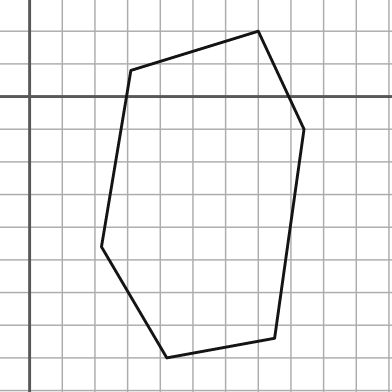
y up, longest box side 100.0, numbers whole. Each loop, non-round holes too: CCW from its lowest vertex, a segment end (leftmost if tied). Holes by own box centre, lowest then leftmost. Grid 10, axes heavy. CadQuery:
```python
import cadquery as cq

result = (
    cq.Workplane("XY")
    .moveTo(42.0, -80.0)
    .lineTo(75.0, -74.0)
    .lineTo(84.0, -10.0)
    .lineTo(70.0, 20.0)
    .lineTo(31.0, 8.0)
    .lineTo(22.0, -46.0)
    .close()
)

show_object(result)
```